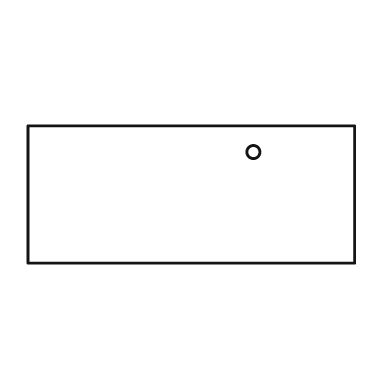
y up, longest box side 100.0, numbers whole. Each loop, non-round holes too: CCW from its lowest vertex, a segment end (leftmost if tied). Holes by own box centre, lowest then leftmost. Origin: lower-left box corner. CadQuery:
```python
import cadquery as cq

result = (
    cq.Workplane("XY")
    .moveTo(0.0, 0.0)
    .lineTo(100.0, 0.0)
    .lineTo(100.0, 42.0)
    .lineTo(0.0, 42.0)
    .close()
    .moveTo(69.0, 34.0)
    .circle(2.0)
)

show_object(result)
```